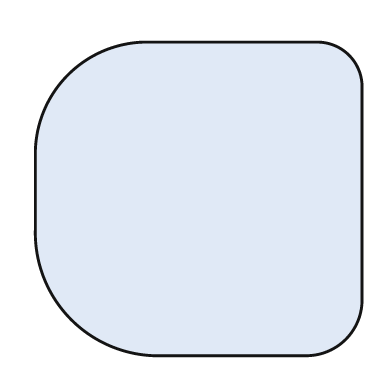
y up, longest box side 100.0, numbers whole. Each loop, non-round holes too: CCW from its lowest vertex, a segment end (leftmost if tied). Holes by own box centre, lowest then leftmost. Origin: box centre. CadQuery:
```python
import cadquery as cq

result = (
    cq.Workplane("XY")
    .moveTo(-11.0, -48.0)
    .lineTo(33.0, -48.0)
    .threePointArc((45.0, -43.0), (50.0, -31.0))
    .lineTo(50.0, 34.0)
    .threePointArc((46.0, 44.0), (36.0, 48.0))
    .lineTo(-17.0, 48.0)
    .threePointArc((-40.0, 38.0), (-50.0, 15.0))
    .lineTo(-50.0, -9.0)
    .threePointArc((-39.0, -37.0), (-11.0, -48.0))
    .close()
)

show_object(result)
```